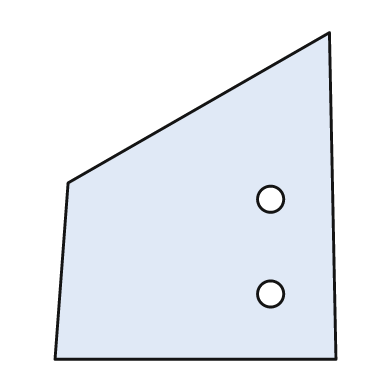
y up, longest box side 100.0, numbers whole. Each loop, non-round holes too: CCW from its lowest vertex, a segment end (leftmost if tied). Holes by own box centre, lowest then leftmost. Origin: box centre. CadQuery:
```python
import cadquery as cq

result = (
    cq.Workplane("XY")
    .moveTo(-43.0, -50.0)
    .lineTo(43.0, -50.0)
    .lineTo(41.0, 50.0)
    .lineTo(-39.0, 4.0)
    .close()
    .moveTo(23.0, -30.0)
    .circle(4.0)
    .moveTo(23.0, -1.0)
    .circle(4.0)
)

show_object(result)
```